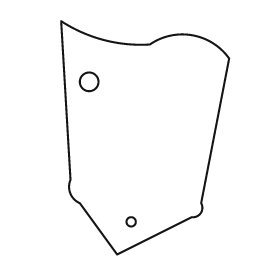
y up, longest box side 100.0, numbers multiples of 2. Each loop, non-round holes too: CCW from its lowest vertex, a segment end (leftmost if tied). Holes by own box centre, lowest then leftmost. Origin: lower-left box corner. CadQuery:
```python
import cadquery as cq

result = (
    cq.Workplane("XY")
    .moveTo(24.0, 0.0)
    .lineTo(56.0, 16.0)
    .threePointArc((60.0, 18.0), (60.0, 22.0))
    .lineTo(72.0, 84.0)
    .threePointArc((56.0, 94.0), (38.0, 90.0))
    .threePointArc((18.0, 92.0), (0.0, 100.0))
    .lineTo(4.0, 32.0)
    .threePointArc((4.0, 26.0), (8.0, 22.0))
    .close()
    .moveTo(30.0, 14.0)
    .circle(2.0)
    .moveTo(12.0, 74.0)
    .circle(4.0)
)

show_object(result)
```